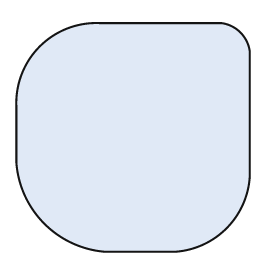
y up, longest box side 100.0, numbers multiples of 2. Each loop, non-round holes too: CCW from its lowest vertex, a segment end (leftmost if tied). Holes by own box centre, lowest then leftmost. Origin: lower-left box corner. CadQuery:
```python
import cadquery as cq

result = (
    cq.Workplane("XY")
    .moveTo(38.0, 0.0)
    .lineTo(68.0, 0.0)
    .threePointArc((90.0, 10.0), (100.0, 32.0))
    .lineTo(100.0, 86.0)
    .threePointArc((96.0, 94.0), (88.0, 98.0))
    .lineTo(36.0, 98.0)
    .threePointArc((10.0, 88.0), (0.0, 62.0))
    .lineTo(0.0, 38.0)
    .threePointArc((12.0, 12.0), (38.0, 0.0))
    .close()
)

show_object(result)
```